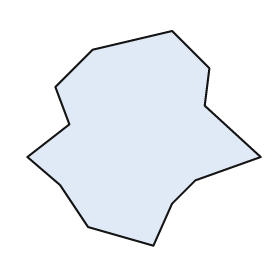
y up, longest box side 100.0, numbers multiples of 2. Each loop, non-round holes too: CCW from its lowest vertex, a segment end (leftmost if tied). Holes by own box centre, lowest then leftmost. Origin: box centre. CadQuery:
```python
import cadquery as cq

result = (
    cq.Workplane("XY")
    .moveTo(4.0, -46.0)
    .lineTo(12.0, -28.0)
    .lineTo(22.0, -18.0)
    .lineTo(50.0, -8.0)
    .lineTo(26.0, 14.0)
    .lineTo(28.0, 30.0)
    .lineTo(12.0, 46.0)
    .lineTo(-22.0, 38.0)
    .lineTo(-38.0, 22.0)
    .lineTo(-32.0, 6.0)
    .lineTo(-50.0, -8.0)
    .lineTo(-36.0, -20.0)
    .lineTo(-24.0, -38.0)
    .close()
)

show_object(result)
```